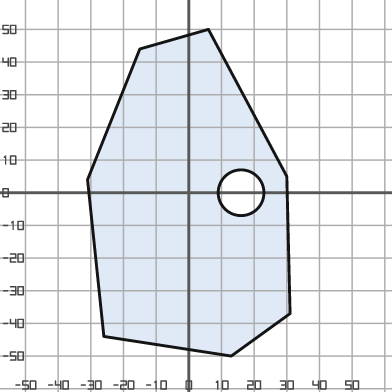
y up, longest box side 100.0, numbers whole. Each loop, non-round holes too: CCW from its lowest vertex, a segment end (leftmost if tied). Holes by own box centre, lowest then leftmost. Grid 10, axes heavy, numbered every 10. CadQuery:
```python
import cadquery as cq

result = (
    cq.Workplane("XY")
    .moveTo(13.0, -50.0)
    .lineTo(31.0, -37.0)
    .lineTo(30.0, 5.0)
    .lineTo(6.0, 50.0)
    .lineTo(-15.0, 44.0)
    .lineTo(-31.0, 4.0)
    .lineTo(-26.0, -44.0)
    .close()
    .moveTo(16.0, 0.0)
    .circle(7.0)
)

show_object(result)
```